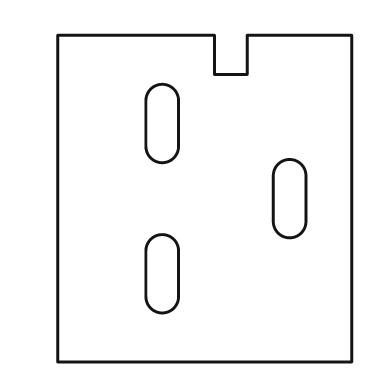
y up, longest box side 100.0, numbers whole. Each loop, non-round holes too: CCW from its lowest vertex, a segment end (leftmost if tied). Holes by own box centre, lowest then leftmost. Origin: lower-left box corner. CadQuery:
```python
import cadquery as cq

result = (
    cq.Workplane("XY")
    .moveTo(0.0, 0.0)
    .lineTo(90.0, 0.0)
    .lineTo(90.0, 100.0)
    .lineTo(58.0, 100.0)
    .lineTo(58.0, 88.0)
    .lineTo(48.0, 88.0)
    .lineTo(48.0, 100.0)
    .lineTo(0.0, 100.0)
    .close()
    .moveTo(27.0, 20.0)
    .threePointArc((32.0, 15.0), (37.0, 20.0))
    .lineTo(37.0, 34.0)
    .threePointArc((32.0, 39.0), (27.0, 34.0))
    .close()
    .moveTo(66.0, 43.0)
    .threePointArc((71.0, 38.0), (76.0, 43.0))
    .lineTo(76.0, 57.0)
    .threePointArc((71.0, 62.0), (66.0, 57.0))
    .close()
    .moveTo(27.0, 66.0)
    .threePointArc((32.0, 61.0), (37.0, 66.0))
    .lineTo(37.0, 80.0)
    .threePointArc((32.0, 85.0), (27.0, 80.0))
    .close()
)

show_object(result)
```